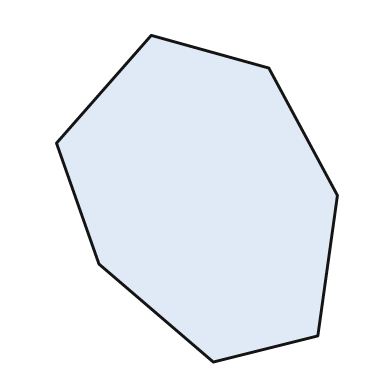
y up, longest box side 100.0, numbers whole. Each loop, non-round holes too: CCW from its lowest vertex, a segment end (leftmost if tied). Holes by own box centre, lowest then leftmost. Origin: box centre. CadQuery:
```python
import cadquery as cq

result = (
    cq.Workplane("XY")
    .moveTo(5.0, -50.0)
    .lineTo(37.0, -42.0)
    .lineTo(43.0, 1.0)
    .lineTo(22.0, 40.0)
    .lineTo(-14.0, 50.0)
    .lineTo(-43.0, 17.0)
    .lineTo(-30.0, -20.0)
    .close()
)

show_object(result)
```